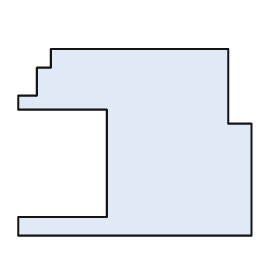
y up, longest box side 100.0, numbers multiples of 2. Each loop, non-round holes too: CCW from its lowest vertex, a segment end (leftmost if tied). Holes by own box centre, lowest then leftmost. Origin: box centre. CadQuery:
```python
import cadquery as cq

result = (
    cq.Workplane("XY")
    .moveTo(-50.0, -40.0)
    .lineTo(50.0, -40.0)
    .lineTo(50.0, 8.0)
    .lineTo(40.0, 8.0)
    .lineTo(40.0, 40.0)
    .lineTo(-36.0, 40.0)
    .lineTo(-36.0, 32.0)
    .lineTo(-42.0, 32.0)
    .lineTo(-42.0, 20.0)
    .lineTo(-50.0, 20.0)
    .lineTo(-50.0, 14.0)
    .lineTo(-12.0, 14.0)
    .lineTo(-12.0, -32.0)
    .lineTo(-50.0, -32.0)
    .close()
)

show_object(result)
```